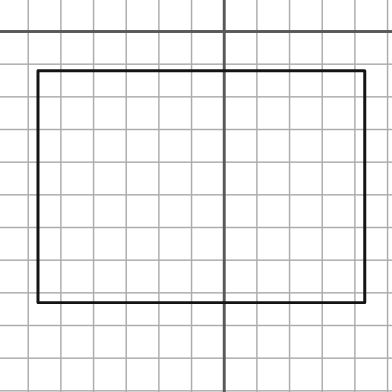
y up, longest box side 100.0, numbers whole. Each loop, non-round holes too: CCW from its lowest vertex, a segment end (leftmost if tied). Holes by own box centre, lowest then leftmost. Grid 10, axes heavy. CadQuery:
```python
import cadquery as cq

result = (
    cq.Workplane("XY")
    .moveTo(-57.0, -83.0)
    .lineTo(43.0, -83.0)
    .lineTo(43.0, -12.0)
    .lineTo(-57.0, -12.0)
    .close()
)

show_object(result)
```